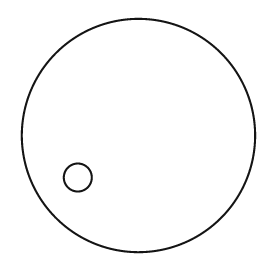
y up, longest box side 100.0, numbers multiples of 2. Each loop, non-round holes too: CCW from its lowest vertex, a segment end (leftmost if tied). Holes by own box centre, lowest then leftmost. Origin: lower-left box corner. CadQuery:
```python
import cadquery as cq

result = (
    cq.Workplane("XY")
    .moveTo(50.0, 50.0)
    .circle(50.0)
    .moveTo(24.0, 32.0)
    .circle(6.0)
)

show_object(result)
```